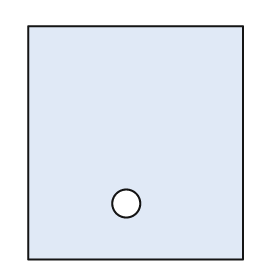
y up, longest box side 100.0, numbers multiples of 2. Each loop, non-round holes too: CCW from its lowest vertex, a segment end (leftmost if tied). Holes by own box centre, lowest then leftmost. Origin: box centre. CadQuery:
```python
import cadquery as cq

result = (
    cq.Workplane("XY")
    .moveTo(-46.0, -50.0)
    .lineTo(46.0, -50.0)
    .lineTo(46.0, 50.0)
    .lineTo(-46.0, 50.0)
    .close()
    .moveTo(-4.0, -26.0)
    .circle(6.0)
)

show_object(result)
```